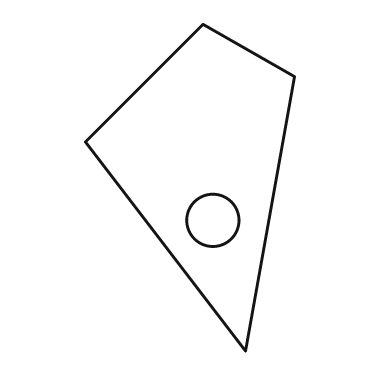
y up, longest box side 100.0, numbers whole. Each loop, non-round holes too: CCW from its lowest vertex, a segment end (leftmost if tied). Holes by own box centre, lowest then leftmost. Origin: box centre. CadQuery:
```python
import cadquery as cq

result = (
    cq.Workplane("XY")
    .moveTo(17.0, -50.0)
    .lineTo(32.0, 34.0)
    .lineTo(4.0, 50.0)
    .lineTo(-32.0, 14.0)
    .close()
    .moveTo(7.0, -10.0)
    .circle(8.0)
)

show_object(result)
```